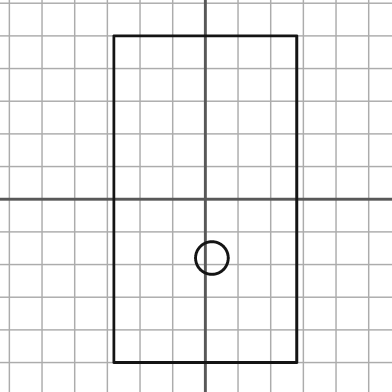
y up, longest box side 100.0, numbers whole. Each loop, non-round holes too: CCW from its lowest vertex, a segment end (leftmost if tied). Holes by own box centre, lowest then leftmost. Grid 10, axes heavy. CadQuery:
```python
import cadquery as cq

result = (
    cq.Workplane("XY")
    .moveTo(-28.0, -50.0)
    .lineTo(28.0, -50.0)
    .lineTo(28.0, 50.0)
    .lineTo(-28.0, 50.0)
    .close()
    .moveTo(2.0, -18.0)
    .circle(5.0)
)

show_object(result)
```